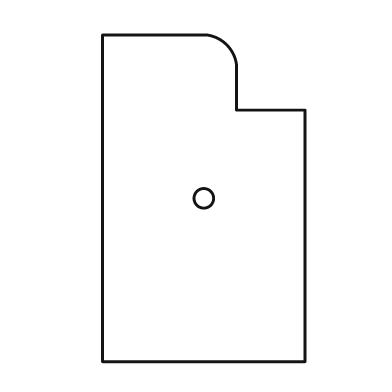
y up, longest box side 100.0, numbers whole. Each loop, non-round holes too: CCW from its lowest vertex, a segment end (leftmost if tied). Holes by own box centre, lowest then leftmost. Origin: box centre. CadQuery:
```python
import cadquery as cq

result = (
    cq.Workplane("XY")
    .moveTo(-31.0, -50.0)
    .lineTo(31.0, -50.0)
    .lineTo(31.0, 27.0)
    .lineTo(10.0, 27.0)
    .lineTo(10.0, 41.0)
    .threePointArc((7.0, 47.0), (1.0, 50.0))
    .lineTo(-31.0, 50.0)
    .close()
    .moveTo(0.0, 0.0)
    .circle(3.0)
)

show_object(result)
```